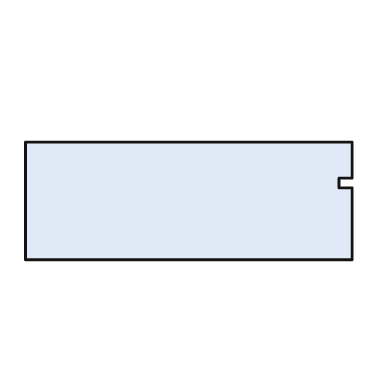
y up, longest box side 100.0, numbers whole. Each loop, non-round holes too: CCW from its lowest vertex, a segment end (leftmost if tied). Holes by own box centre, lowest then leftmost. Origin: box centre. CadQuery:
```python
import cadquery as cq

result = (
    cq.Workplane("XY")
    .moveTo(-50.0, -18.0)
    .lineTo(50.0, -18.0)
    .lineTo(50.0, 4.0)
    .lineTo(46.0, 4.0)
    .lineTo(46.0, 7.0)
    .lineTo(50.0, 7.0)
    .lineTo(50.0, 18.0)
    .lineTo(-50.0, 18.0)
    .close()
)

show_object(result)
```